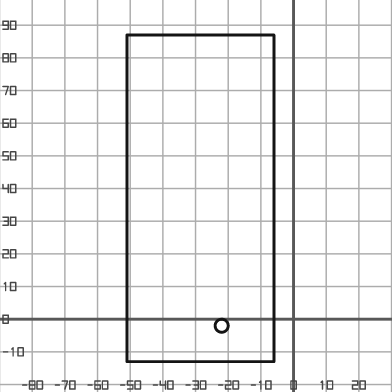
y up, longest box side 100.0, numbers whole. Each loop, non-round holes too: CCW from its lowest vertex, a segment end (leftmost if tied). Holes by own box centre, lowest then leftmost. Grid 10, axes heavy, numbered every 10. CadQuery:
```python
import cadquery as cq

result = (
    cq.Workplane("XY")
    .moveTo(-51.0, -13.0)
    .lineTo(-6.0, -13.0)
    .lineTo(-6.0, 87.0)
    .lineTo(-51.0, 87.0)
    .close()
    .moveTo(-22.0, -2.0)
    .circle(2.0)
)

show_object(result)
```